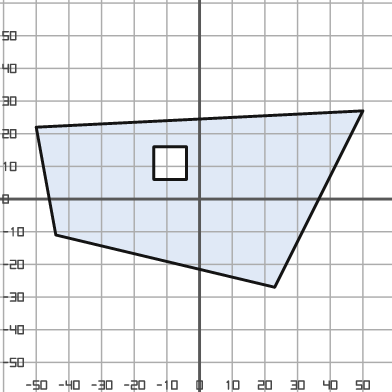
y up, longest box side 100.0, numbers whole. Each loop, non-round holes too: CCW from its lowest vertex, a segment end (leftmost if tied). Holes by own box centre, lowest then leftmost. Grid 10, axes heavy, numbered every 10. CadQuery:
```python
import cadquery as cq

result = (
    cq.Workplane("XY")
    .moveTo(23.0, -27.0)
    .lineTo(50.0, 27.0)
    .lineTo(-50.0, 22.0)
    .lineTo(-44.0, -11.0)
    .close()
    .moveTo(-14.0, 6.0)
    .lineTo(-4.0, 6.0)
    .lineTo(-4.0, 16.0)
    .lineTo(-14.0, 16.0)
    .close()
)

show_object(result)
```